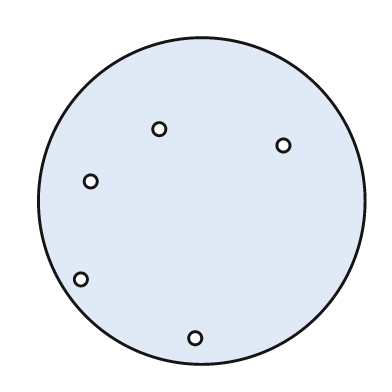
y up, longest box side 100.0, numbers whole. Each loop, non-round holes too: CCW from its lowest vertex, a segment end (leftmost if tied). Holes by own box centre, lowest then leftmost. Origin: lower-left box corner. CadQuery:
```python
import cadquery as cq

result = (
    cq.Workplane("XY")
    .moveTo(50.0, 50.0)
    .circle(50.0)
    .moveTo(48.0, 8.0)
    .circle(2.0)
    .moveTo(13.0, 26.0)
    .circle(2.0)
    .moveTo(16.0, 56.0)
    .circle(2.0)
    .moveTo(75.0, 67.0)
    .circle(2.0)
    .moveTo(37.0, 72.0)
    .circle(2.0)
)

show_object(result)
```